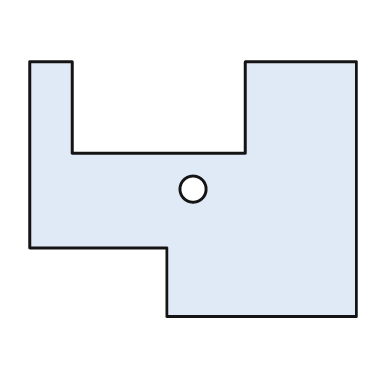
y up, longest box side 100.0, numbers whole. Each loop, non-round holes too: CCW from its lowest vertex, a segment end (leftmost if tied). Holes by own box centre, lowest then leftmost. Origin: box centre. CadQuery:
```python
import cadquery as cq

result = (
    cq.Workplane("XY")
    .moveTo(-8.0, -39.0)
    .lineTo(50.0, -39.0)
    .lineTo(50.0, 39.0)
    .lineTo(16.0, 39.0)
    .lineTo(16.0, 11.0)
    .lineTo(-37.0, 11.0)
    .lineTo(-37.0, 39.0)
    .lineTo(-50.0, 39.0)
    .lineTo(-50.0, -18.0)
    .lineTo(-8.0, -18.0)
    .close()
    .moveTo(0.0, 0.0)
    .circle(4.0)
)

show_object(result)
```